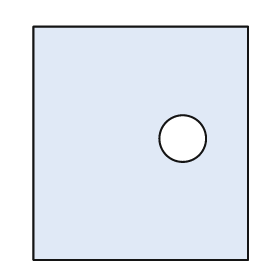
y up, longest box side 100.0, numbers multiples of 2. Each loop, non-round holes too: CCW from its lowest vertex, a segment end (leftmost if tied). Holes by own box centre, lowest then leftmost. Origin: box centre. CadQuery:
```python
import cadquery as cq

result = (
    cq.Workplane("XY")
    .moveTo(-46.0, -50.0)
    .lineTo(46.0, -50.0)
    .lineTo(46.0, 50.0)
    .lineTo(-46.0, 50.0)
    .close()
    .moveTo(18.0, 2.0)
    .circle(10.0)
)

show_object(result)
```